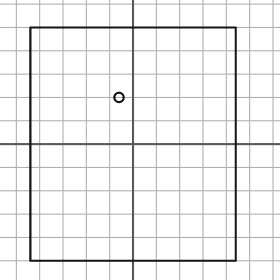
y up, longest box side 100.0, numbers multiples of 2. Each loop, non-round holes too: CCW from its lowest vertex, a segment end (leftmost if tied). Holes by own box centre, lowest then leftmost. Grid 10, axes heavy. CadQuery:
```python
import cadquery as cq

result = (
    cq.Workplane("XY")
    .moveTo(-44.0, -50.0)
    .lineTo(44.0, -50.0)
    .lineTo(44.0, 50.0)
    .lineTo(-44.0, 50.0)
    .close()
    .moveTo(-6.0, 20.0)
    .circle(2.0)
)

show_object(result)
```